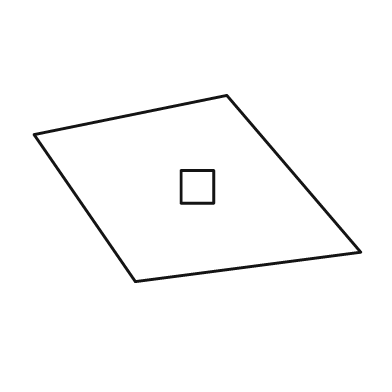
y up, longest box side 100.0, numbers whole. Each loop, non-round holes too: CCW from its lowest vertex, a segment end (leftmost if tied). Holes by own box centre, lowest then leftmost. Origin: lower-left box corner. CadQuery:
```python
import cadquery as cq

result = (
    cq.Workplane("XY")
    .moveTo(31.0, 0.0)
    .lineTo(100.0, 9.0)
    .lineTo(59.0, 57.0)
    .lineTo(0.0, 45.0)
    .close()
    .moveTo(45.0, 24.0)
    .lineTo(55.0, 24.0)
    .lineTo(55.0, 34.0)
    .lineTo(45.0, 34.0)
    .close()
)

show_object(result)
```